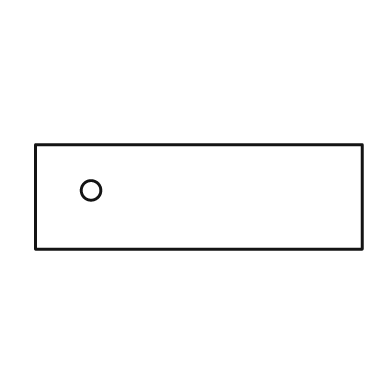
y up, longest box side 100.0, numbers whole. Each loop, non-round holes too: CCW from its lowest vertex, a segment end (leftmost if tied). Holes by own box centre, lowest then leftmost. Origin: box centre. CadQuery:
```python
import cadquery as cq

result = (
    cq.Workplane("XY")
    .moveTo(-50.0, -16.0)
    .lineTo(50.0, -16.0)
    .lineTo(50.0, 16.0)
    .lineTo(-50.0, 16.0)
    .close()
    .moveTo(-33.0, 2.0)
    .circle(3.0)
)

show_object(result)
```